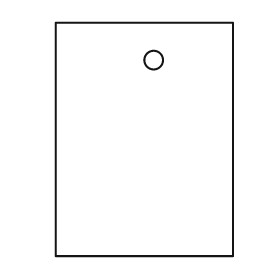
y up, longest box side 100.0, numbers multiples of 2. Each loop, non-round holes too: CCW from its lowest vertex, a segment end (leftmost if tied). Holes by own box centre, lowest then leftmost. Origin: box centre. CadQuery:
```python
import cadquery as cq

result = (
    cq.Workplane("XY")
    .moveTo(-38.0, -50.0)
    .lineTo(38.0, -50.0)
    .lineTo(38.0, 50.0)
    .lineTo(-38.0, 50.0)
    .close()
    .moveTo(4.0, 34.0)
    .circle(4.0)
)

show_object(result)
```